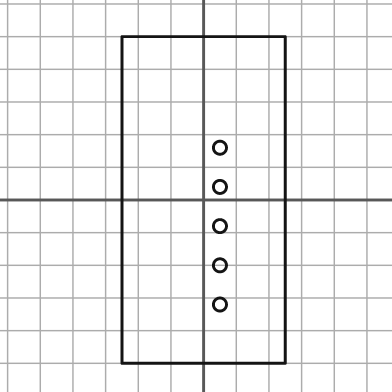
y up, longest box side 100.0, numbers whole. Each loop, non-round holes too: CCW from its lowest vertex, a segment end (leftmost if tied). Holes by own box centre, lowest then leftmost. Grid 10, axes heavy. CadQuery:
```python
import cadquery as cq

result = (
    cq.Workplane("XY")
    .moveTo(-25.0, -50.0)
    .lineTo(25.0, -50.0)
    .lineTo(25.0, 50.0)
    .lineTo(-25.0, 50.0)
    .close()
    .moveTo(5.0, -32.0)
    .circle(2.0)
    .moveTo(5.0, -20.0)
    .circle(2.0)
    .moveTo(5.0, -8.0)
    .circle(2.0)
    .moveTo(5.0, 4.0)
    .circle(2.0)
    .moveTo(5.0, 16.0)
    .circle(2.0)
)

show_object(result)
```